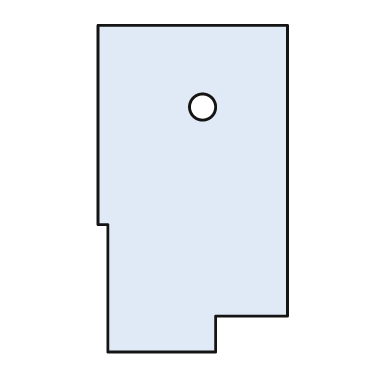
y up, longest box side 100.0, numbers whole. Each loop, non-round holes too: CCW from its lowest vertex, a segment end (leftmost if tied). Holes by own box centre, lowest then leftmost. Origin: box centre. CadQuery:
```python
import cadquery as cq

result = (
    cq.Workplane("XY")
    .moveTo(-26.0, -50.0)
    .lineTo(7.0, -50.0)
    .lineTo(7.0, -39.0)
    .lineTo(29.0, -39.0)
    .lineTo(29.0, 50.0)
    .lineTo(-29.0, 50.0)
    .lineTo(-29.0, -11.0)
    .lineTo(-26.0, -11.0)
    .close()
    .moveTo(3.0, 25.0)
    .circle(4.0)
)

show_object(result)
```